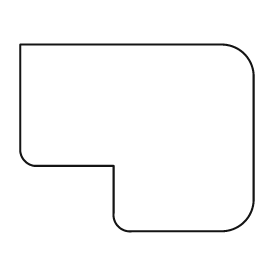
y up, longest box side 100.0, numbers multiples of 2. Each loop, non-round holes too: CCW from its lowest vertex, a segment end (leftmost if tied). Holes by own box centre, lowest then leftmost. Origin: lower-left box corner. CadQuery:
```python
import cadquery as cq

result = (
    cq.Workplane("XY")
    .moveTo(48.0, 0.0)
    .lineTo(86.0, 0.0)
    .threePointArc((96.0, 4.0), (100.0, 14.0))
    .lineTo(100.0, 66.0)
    .threePointArc((96.0, 76.0), (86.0, 80.0))
    .lineTo(0.0, 80.0)
    .lineTo(0.0, 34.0)
    .threePointArc((2.0, 30.0), (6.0, 28.0))
    .lineTo(40.0, 28.0)
    .lineTo(40.0, 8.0)
    .threePointArc((42.0, 2.0), (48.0, 0.0))
    .close()
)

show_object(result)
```